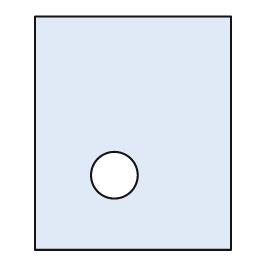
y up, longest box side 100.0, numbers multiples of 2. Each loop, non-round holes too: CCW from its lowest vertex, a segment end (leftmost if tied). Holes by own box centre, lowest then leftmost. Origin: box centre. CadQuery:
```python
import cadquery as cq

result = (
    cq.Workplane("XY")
    .moveTo(-42.0, -50.0)
    .lineTo(42.0, -50.0)
    .lineTo(42.0, 50.0)
    .lineTo(-42.0, 50.0)
    .close()
    .moveTo(-8.0, -18.0)
    .circle(10.0)
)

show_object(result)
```